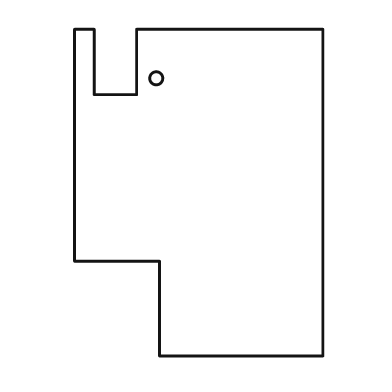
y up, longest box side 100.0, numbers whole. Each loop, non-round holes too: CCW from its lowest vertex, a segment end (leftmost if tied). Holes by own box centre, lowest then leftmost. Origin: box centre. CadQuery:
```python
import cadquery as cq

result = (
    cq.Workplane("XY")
    .moveTo(-12.0, -50.0)
    .lineTo(38.0, -50.0)
    .lineTo(38.0, 50.0)
    .lineTo(-19.0, 50.0)
    .lineTo(-19.0, 30.0)
    .lineTo(-32.0, 30.0)
    .lineTo(-32.0, 50.0)
    .lineTo(-38.0, 50.0)
    .lineTo(-38.0, -21.0)
    .lineTo(-12.0, -21.0)
    .close()
    .moveTo(-13.0, 35.0)
    .circle(2.0)
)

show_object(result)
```